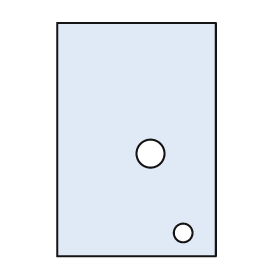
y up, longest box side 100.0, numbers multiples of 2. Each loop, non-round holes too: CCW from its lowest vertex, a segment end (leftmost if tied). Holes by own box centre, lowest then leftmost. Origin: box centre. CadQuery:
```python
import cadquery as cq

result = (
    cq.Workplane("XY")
    .moveTo(-34.0, -50.0)
    .lineTo(34.0, -50.0)
    .lineTo(34.0, 50.0)
    .lineTo(-34.0, 50.0)
    .close()
    .moveTo(20.0, -40.0)
    .circle(4.0)
    .moveTo(6.0, -6.0)
    .circle(6.0)
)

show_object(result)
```